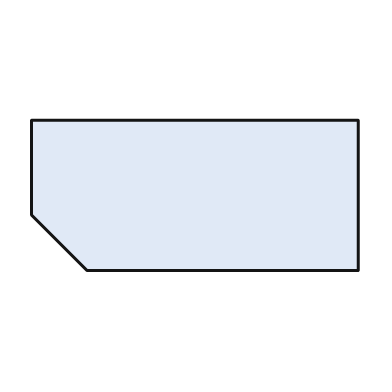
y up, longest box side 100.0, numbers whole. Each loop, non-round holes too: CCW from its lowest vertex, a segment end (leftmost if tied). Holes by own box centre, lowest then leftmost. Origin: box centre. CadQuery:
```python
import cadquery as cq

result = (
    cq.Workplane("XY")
    .moveTo(-33.0, -23.0)
    .lineTo(50.0, -23.0)
    .lineTo(50.0, 23.0)
    .lineTo(-50.0, 23.0)
    .lineTo(-50.0, -6.0)
    .close()
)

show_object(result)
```